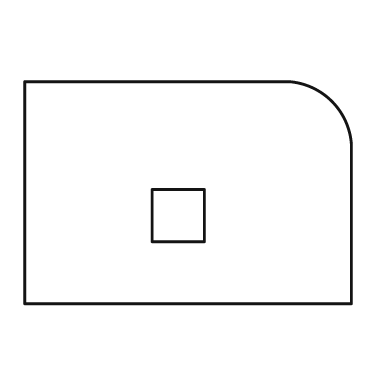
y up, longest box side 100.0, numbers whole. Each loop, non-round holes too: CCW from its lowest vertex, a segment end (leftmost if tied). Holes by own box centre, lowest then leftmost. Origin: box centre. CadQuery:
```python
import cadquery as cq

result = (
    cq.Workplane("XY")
    .moveTo(-50.0, -34.0)
    .lineTo(50.0, -34.0)
    .lineTo(50.0, 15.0)
    .threePointArc((44.0, 28.0), (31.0, 34.0))
    .lineTo(-50.0, 34.0)
    .close()
    .moveTo(-11.0, -15.0)
    .lineTo(5.0, -15.0)
    .lineTo(5.0, 1.0)
    .lineTo(-11.0, 1.0)
    .close()
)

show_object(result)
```